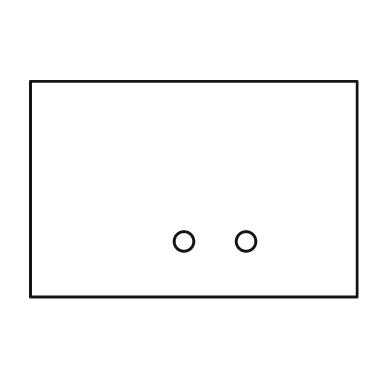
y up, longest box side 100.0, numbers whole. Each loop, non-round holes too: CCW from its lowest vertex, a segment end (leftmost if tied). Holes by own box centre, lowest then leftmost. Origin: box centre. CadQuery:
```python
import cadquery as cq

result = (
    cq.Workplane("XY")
    .moveTo(-50.0, -33.0)
    .lineTo(50.0, -33.0)
    .lineTo(50.0, 33.0)
    .lineTo(-50.0, 33.0)
    .close()
    .moveTo(-3.0, -16.0)
    .circle(3.0)
    .moveTo(16.0, -16.0)
    .circle(3.0)
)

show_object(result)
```